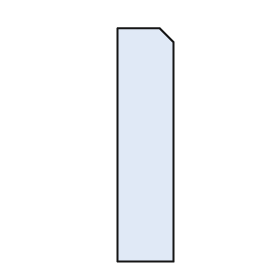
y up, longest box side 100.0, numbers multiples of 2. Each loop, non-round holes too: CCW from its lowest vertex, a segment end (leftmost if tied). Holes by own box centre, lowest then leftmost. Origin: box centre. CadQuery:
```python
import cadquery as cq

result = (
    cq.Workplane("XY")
    .moveTo(-12.0, -50.0)
    .lineTo(12.0, -50.0)
    .lineTo(12.0, 44.0)
    .lineTo(6.0, 50.0)
    .lineTo(-12.0, 50.0)
    .close()
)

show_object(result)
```